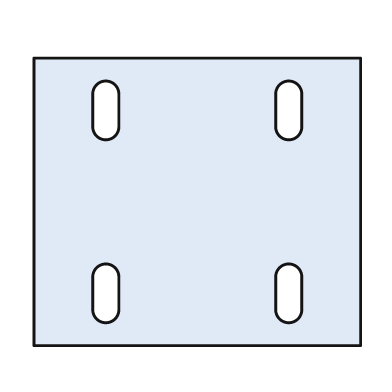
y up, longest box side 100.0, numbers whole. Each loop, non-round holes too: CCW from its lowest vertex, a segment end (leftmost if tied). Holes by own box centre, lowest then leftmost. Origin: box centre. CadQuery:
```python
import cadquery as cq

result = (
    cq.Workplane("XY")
    .moveTo(-50.0, -44.0)
    .lineTo(50.0, -44.0)
    .lineTo(50.0, 44.0)
    .lineTo(-50.0, 44.0)
    .close()
    .moveTo(-32.0, -33.0)
    .threePointArc((-28.0, -37.0), (-24.0, -33.0))
    .lineTo(-24.0, -23.0)
    .threePointArc((-28.0, -19.0), (-32.0, -23.0))
    .close()
    .moveTo(24.0, -33.0)
    .threePointArc((28.0, -37.0), (32.0, -33.0))
    .lineTo(32.0, -23.0)
    .threePointArc((28.0, -19.0), (24.0, -23.0))
    .close()
    .moveTo(-32.0, 23.0)
    .threePointArc((-28.0, 19.0), (-24.0, 23.0))
    .lineTo(-24.0, 33.0)
    .threePointArc((-28.0, 37.0), (-32.0, 33.0))
    .close()
    .moveTo(24.0, 23.0)
    .threePointArc((28.0, 19.0), (32.0, 23.0))
    .lineTo(32.0, 33.0)
    .threePointArc((28.0, 37.0), (24.0, 33.0))
    .close()
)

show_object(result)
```